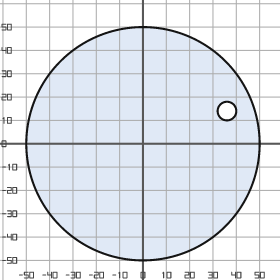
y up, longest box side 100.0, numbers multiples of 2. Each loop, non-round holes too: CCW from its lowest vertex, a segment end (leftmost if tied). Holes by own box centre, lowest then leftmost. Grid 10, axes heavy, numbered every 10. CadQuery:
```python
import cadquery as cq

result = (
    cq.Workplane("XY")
    .moveTo(0.0, 0.0)
    .circle(50.0)
    .moveTo(36.0, 14.0)
    .circle(4.0)
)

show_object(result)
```